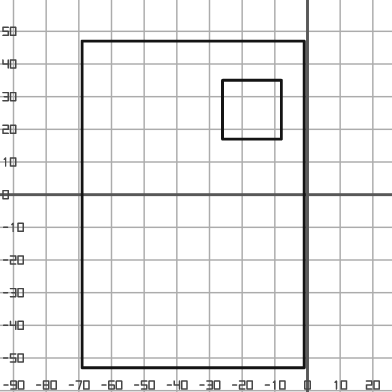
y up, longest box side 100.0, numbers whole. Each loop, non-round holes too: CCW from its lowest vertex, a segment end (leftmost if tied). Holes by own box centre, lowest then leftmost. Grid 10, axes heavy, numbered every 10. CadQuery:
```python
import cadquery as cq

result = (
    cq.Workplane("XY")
    .moveTo(-69.0, -53.0)
    .lineTo(-1.0, -53.0)
    .lineTo(-1.0, 47.0)
    .lineTo(-69.0, 47.0)
    .close()
    .moveTo(-26.0, 17.0)
    .lineTo(-8.0, 17.0)
    .lineTo(-8.0, 35.0)
    .lineTo(-26.0, 35.0)
    .close()
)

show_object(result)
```